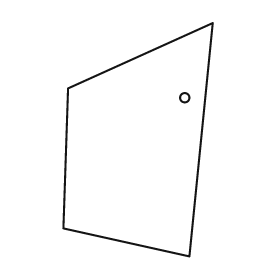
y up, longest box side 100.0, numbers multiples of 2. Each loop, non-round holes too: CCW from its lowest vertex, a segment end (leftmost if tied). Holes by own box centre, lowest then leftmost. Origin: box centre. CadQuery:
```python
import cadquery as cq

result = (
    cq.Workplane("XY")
    .moveTo(22.0, -50.0)
    .lineTo(32.0, 50.0)
    .lineTo(-30.0, 22.0)
    .lineTo(-32.0, -38.0)
    .close()
    .moveTo(20.0, 18.0)
    .circle(2.0)
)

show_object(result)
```